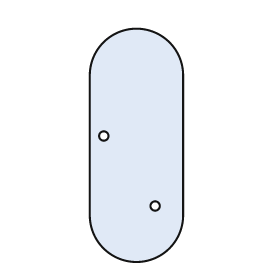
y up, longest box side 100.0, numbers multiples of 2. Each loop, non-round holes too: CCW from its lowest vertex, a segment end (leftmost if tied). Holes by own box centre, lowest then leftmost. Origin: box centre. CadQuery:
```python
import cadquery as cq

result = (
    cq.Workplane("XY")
    .moveTo(-20.0, -30.0)
    .threePointArc((0.0, -50.0), (20.0, -30.0))
    .lineTo(20.0, 30.0)
    .threePointArc((0.0, 50.0), (-20.0, 30.0))
    .close()
    .moveTo(8.0, -26.0)
    .circle(2.0)
    .moveTo(-14.0, 4.0)
    .circle(2.0)
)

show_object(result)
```